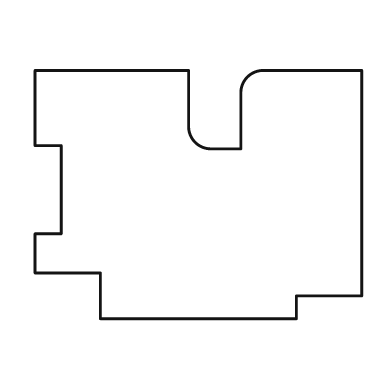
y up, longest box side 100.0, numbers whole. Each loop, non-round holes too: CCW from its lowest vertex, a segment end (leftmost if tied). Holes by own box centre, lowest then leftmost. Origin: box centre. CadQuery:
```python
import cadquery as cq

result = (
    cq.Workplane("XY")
    .moveTo(-30.0, -38.0)
    .lineTo(30.0, -38.0)
    .lineTo(30.0, -31.0)
    .lineTo(50.0, -31.0)
    .lineTo(50.0, 38.0)
    .lineTo(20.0, 38.0)
    .threePointArc((15.0, 36.0), (13.0, 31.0))
    .lineTo(13.0, 14.0)
    .lineTo(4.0, 14.0)
    .threePointArc((-1.0, 16.0), (-3.0, 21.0))
    .lineTo(-3.0, 38.0)
    .lineTo(-50.0, 38.0)
    .lineTo(-50.0, 15.0)
    .lineTo(-42.0, 15.0)
    .lineTo(-42.0, -12.0)
    .lineTo(-50.0, -12.0)
    .lineTo(-50.0, -24.0)
    .lineTo(-30.0, -24.0)
    .close()
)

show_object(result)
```